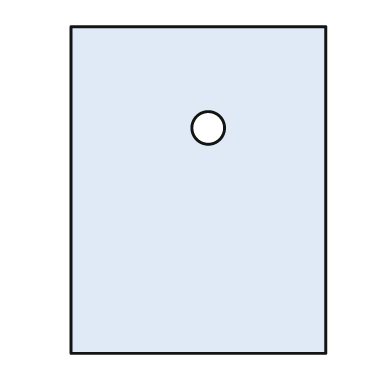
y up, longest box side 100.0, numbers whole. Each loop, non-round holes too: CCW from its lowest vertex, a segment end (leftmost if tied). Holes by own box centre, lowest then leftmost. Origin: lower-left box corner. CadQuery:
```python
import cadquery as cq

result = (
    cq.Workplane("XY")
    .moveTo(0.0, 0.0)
    .lineTo(78.0, 0.0)
    .lineTo(78.0, 100.0)
    .lineTo(0.0, 100.0)
    .close()
    .moveTo(42.0, 69.0)
    .circle(5.0)
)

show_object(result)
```